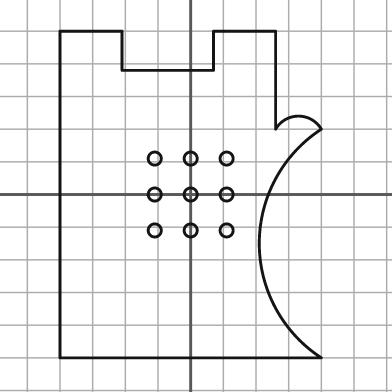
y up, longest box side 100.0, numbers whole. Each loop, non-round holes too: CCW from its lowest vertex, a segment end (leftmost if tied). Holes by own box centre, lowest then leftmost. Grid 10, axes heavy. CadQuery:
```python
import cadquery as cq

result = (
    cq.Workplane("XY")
    .moveTo(-40.0, -50.0)
    .lineTo(40.0, -50.0)
    .threePointArc((21.0, -15.0), (40.0, 20.0))
    .threePointArc((33.0, 24.0), (26.0, 20.0))
    .lineTo(26.0, 50.0)
    .lineTo(7.0, 50.0)
    .lineTo(7.0, 38.0)
    .lineTo(-21.0, 38.0)
    .lineTo(-21.0, 50.0)
    .lineTo(-40.0, 50.0)
    .close()
    .moveTo(-11.0, -11.0)
    .circle(2.0)
    .moveTo(0.0, -11.0)
    .circle(2.0)
    .moveTo(11.0, -11.0)
    .circle(2.0)
    .moveTo(-11.0, 0.0)
    .circle(2.0)
    .moveTo(0.0, 0.0)
    .circle(2.0)
    .moveTo(11.0, 0.0)
    .circle(2.0)
    .moveTo(-11.0, 11.0)
    .circle(2.0)
    .moveTo(0.0, 11.0)
    .circle(2.0)
    .moveTo(11.0, 11.0)
    .circle(2.0)
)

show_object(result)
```